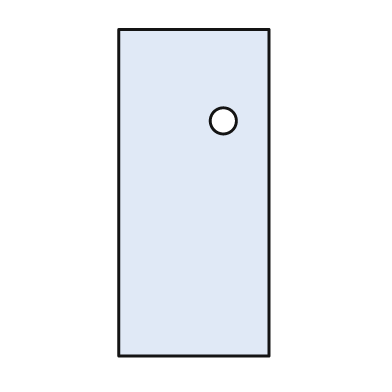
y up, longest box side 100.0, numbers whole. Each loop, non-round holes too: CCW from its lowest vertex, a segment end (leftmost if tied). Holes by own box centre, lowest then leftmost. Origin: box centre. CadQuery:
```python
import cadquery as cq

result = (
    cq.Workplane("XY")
    .moveTo(-23.0, -50.0)
    .lineTo(23.0, -50.0)
    .lineTo(23.0, 50.0)
    .lineTo(-23.0, 50.0)
    .close()
    .moveTo(9.0, 22.0)
    .circle(4.0)
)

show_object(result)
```